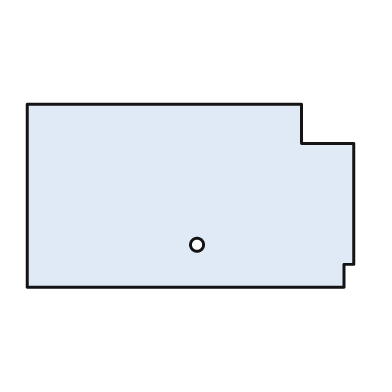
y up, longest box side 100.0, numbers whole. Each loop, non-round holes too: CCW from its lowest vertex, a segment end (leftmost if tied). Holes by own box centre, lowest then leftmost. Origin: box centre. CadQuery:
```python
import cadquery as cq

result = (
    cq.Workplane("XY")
    .moveTo(-50.0, -28.0)
    .lineTo(47.0, -28.0)
    .lineTo(47.0, -21.0)
    .lineTo(50.0, -21.0)
    .lineTo(50.0, 16.0)
    .lineTo(34.0, 16.0)
    .lineTo(34.0, 28.0)
    .lineTo(-50.0, 28.0)
    .close()
    .moveTo(2.0, -15.0)
    .circle(2.0)
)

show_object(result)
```